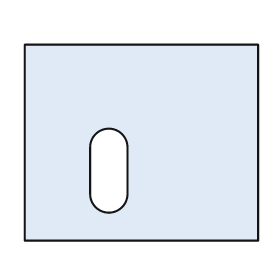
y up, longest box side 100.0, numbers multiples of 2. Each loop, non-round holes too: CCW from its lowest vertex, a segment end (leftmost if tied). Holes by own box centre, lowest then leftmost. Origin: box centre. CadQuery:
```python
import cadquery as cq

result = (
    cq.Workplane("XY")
    .moveTo(-50.0, -42.0)
    .lineTo(50.0, -42.0)
    .lineTo(50.0, 42.0)
    .lineTo(-50.0, 42.0)
    .close()
    .moveTo(-22.0, -22.0)
    .threePointArc((-14.0, -30.0), (-6.0, -22.0))
    .lineTo(-6.0, -2.0)
    .threePointArc((-14.0, 6.0), (-22.0, -2.0))
    .close()
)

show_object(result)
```